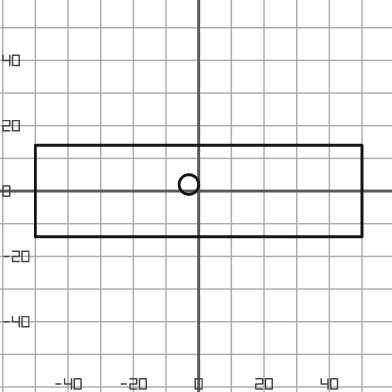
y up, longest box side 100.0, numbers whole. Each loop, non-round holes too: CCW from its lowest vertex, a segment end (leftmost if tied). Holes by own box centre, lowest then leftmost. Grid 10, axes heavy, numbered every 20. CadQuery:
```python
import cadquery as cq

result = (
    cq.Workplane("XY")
    .moveTo(-50.0, -14.0)
    .lineTo(50.0, -14.0)
    .lineTo(50.0, 14.0)
    .lineTo(-50.0, 14.0)
    .close()
    .moveTo(-3.0, 2.0)
    .circle(3.0)
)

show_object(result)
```